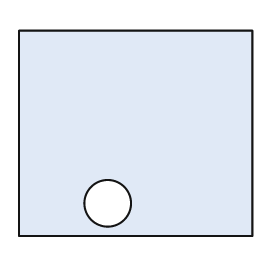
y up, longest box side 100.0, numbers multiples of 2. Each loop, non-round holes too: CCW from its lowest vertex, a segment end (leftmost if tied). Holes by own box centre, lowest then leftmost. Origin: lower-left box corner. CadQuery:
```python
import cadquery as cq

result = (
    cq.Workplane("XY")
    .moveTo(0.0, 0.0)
    .lineTo(100.0, 0.0)
    .lineTo(100.0, 88.0)
    .lineTo(0.0, 88.0)
    .close()
    .moveTo(38.0, 14.0)
    .circle(10.0)
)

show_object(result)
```